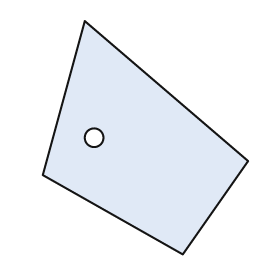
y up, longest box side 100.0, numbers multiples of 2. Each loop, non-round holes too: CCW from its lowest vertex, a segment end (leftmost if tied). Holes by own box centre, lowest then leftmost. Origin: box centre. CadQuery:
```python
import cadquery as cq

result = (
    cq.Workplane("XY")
    .moveTo(16.0, -50.0)
    .lineTo(44.0, -10.0)
    .lineTo(-26.0, 50.0)
    .lineTo(-44.0, -16.0)
    .close()
    .moveTo(-22.0, 0.0)
    .circle(4.0)
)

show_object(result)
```